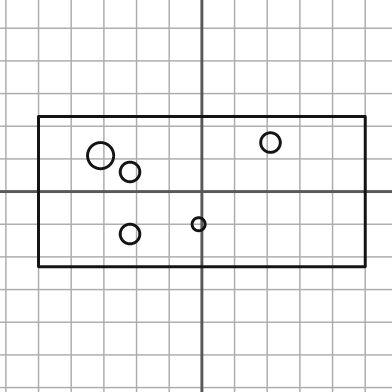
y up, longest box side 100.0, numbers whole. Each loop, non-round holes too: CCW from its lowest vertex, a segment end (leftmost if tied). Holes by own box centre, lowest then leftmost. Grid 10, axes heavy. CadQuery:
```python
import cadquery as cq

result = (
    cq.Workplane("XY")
    .moveTo(-50.0, -23.0)
    .lineTo(50.0, -23.0)
    .lineTo(50.0, 23.0)
    .lineTo(-50.0, 23.0)
    .close()
    .moveTo(-22.0, -13.0)
    .circle(3.0)
    .moveTo(-1.0, -10.0)
    .circle(2.0)
    .moveTo(-22.0, 6.0)
    .circle(3.0)
    .moveTo(-31.0, 11.0)
    .circle(4.0)
    .moveTo(21.0, 15.0)
    .circle(3.0)
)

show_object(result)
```